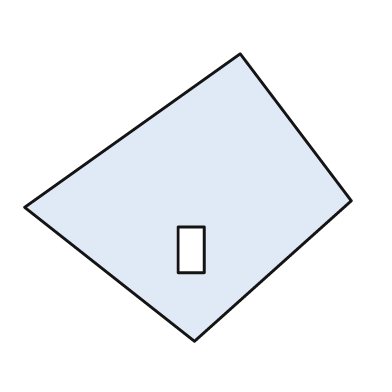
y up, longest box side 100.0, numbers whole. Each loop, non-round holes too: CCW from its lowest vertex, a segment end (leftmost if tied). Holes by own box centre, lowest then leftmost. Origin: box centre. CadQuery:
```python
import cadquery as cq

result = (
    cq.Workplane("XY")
    .moveTo(2.0, -44.0)
    .lineTo(50.0, -1.0)
    .lineTo(16.0, 44.0)
    .lineTo(-50.0, -3.0)
    .close()
    .moveTo(-3.0, -23.0)
    .lineTo(5.0, -23.0)
    .lineTo(5.0, -9.0)
    .lineTo(-3.0, -9.0)
    .close()
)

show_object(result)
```